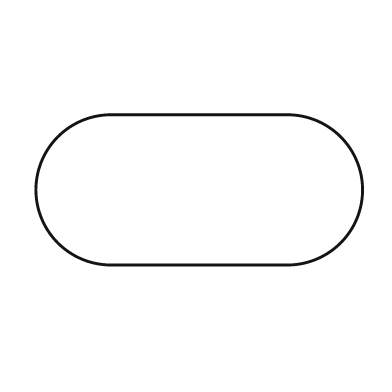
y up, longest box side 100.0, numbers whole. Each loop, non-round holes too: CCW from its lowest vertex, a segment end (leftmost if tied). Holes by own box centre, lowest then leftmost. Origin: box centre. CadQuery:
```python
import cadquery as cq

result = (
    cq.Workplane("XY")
    .moveTo(-27.0, -23.0)
    .lineTo(27.0, -23.0)
    .threePointArc((50.0, 0.0), (27.0, 23.0))
    .lineTo(-27.0, 23.0)
    .threePointArc((-50.0, 0.0), (-27.0, -23.0))
    .close()
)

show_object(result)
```